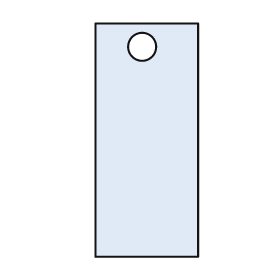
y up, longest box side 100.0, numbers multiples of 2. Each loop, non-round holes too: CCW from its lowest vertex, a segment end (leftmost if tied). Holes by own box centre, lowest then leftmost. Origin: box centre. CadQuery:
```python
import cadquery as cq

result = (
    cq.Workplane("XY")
    .moveTo(-22.0, -50.0)
    .lineTo(22.0, -50.0)
    .lineTo(22.0, 50.0)
    .lineTo(-22.0, 50.0)
    .close()
    .moveTo(-2.0, 40.0)
    .circle(6.0)
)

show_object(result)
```